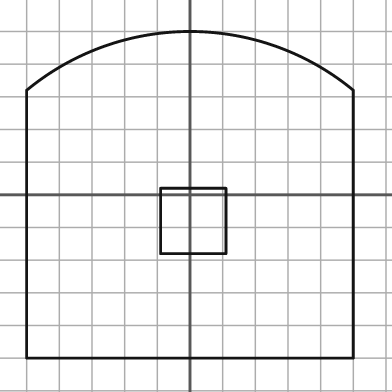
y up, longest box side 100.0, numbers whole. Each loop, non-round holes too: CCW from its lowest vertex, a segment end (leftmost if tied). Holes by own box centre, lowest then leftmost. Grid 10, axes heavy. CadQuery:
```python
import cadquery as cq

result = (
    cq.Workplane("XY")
    .moveTo(-50.0, -50.0)
    .lineTo(50.0, -50.0)
    .lineTo(50.0, 32.0)
    .threePointArc((0.0, 50.0), (-50.0, 32.0))
    .close()
    .moveTo(-9.0, -18.0)
    .lineTo(11.0, -18.0)
    .lineTo(11.0, 2.0)
    .lineTo(-9.0, 2.0)
    .close()
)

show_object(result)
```